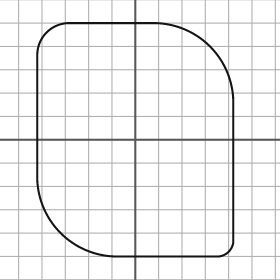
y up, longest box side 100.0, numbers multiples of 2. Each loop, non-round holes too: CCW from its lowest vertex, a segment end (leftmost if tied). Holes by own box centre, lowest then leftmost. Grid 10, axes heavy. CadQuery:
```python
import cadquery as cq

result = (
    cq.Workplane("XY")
    .moveTo(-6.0, -50.0)
    .lineTo(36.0, -50.0)
    .threePointArc((40.0, -48.0), (42.0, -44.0))
    .lineTo(42.0, 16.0)
    .threePointArc((32.0, 40.0), (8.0, 50.0))
    .lineTo(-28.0, 50.0)
    .threePointArc((-38.0, 46.0), (-42.0, 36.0))
    .lineTo(-42.0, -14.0)
    .threePointArc((-32.0, -40.0), (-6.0, -50.0))
    .close()
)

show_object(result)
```